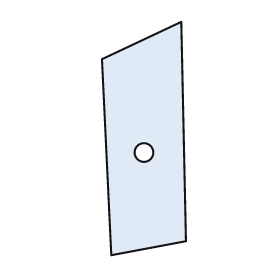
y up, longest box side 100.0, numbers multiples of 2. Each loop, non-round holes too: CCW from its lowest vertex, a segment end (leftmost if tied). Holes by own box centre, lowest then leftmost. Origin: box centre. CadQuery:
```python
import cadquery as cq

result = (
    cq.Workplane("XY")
    .moveTo(-14.0, -50.0)
    .lineTo(18.0, -44.0)
    .lineTo(16.0, 50.0)
    .lineTo(-18.0, 34.0)
    .close()
    .moveTo(0.0, -6.0)
    .circle(4.0)
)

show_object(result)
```